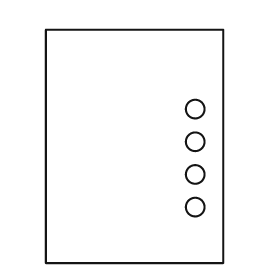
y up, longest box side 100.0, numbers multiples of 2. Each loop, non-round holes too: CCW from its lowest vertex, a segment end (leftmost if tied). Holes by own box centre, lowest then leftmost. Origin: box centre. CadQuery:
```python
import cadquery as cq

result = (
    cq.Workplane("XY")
    .moveTo(-38.0, -50.0)
    .lineTo(38.0, -50.0)
    .lineTo(38.0, 50.0)
    .lineTo(-38.0, 50.0)
    .close()
    .moveTo(26.0, -26.0)
    .circle(4.0)
    .moveTo(26.0, -12.0)
    .circle(4.0)
    .moveTo(26.0, 2.0)
    .circle(4.0)
    .moveTo(26.0, 16.0)
    .circle(4.0)
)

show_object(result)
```